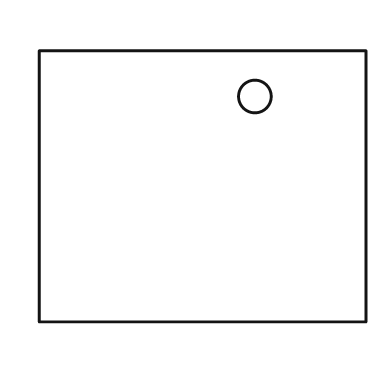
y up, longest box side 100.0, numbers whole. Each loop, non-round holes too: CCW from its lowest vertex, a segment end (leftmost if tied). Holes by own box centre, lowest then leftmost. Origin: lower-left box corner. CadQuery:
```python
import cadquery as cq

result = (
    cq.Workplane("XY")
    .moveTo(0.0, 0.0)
    .lineTo(100.0, 0.0)
    .lineTo(100.0, 83.0)
    .lineTo(0.0, 83.0)
    .close()
    .moveTo(66.0, 69.0)
    .circle(5.0)
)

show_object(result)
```